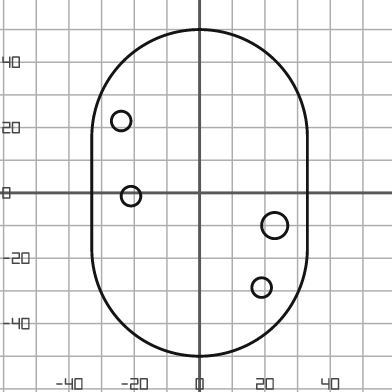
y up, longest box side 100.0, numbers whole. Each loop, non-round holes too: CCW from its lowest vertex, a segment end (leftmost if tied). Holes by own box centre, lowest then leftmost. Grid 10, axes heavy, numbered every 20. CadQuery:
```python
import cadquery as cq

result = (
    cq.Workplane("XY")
    .moveTo(-33.0, -17.0)
    .threePointArc((0.0, -50.0), (33.0, -17.0))
    .lineTo(33.0, 17.0)
    .threePointArc((0.0, 50.0), (-33.0, 17.0))
    .close()
    .moveTo(19.0, -29.0)
    .circle(3.0)
    .moveTo(23.0, -10.0)
    .circle(4.0)
    .moveTo(-21.0, -1.0)
    .circle(3.0)
    .moveTo(-24.0, 22.0)
    .circle(3.0)
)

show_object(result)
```